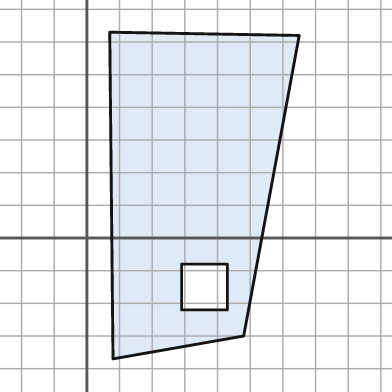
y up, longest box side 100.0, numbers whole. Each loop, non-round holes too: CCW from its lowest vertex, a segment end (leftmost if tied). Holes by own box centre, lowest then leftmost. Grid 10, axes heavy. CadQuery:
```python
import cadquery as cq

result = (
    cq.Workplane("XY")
    .moveTo(8.0, -37.0)
    .lineTo(48.0, -30.0)
    .lineTo(65.0, 62.0)
    .lineTo(7.0, 63.0)
    .close()
    .moveTo(29.0, -22.0)
    .lineTo(43.0, -22.0)
    .lineTo(43.0, -8.0)
    .lineTo(29.0, -8.0)
    .close()
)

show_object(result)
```